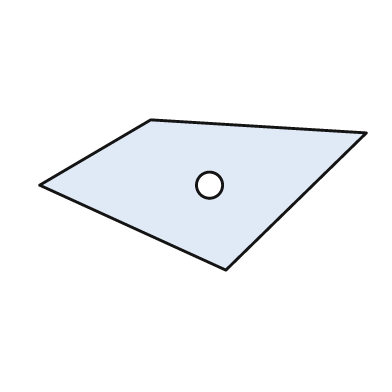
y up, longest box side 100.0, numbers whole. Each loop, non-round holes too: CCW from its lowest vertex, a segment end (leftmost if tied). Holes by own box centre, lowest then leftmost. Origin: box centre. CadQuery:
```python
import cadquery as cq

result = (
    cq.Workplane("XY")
    .moveTo(7.0, -23.0)
    .lineTo(50.0, 19.0)
    .lineTo(-16.0, 23.0)
    .lineTo(-50.0, 3.0)
    .close()
    .moveTo(2.0, 3.0)
    .circle(4.0)
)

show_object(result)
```